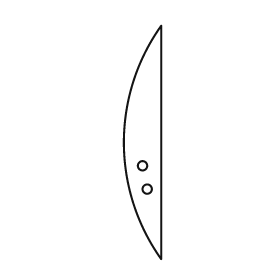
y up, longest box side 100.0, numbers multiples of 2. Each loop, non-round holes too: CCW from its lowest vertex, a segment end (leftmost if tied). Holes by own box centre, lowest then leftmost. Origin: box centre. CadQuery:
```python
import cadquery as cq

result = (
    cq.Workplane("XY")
    .moveTo(8.0, -50.0)
    .lineTo(8.0, 50.0)
    .threePointArc((-8.0, 0.0), (8.0, -50.0))
    .close()
    .moveTo(2.0, -20.0)
    .circle(2.0)
    .moveTo(0.0, -10.0)
    .circle(2.0)
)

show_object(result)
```